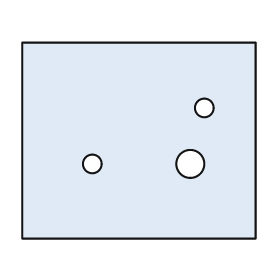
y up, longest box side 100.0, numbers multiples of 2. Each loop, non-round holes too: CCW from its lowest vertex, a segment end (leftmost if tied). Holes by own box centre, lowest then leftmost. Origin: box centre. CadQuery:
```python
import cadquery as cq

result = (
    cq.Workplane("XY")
    .moveTo(-50.0, -42.0)
    .lineTo(50.0, -42.0)
    .lineTo(50.0, 42.0)
    .lineTo(-50.0, 42.0)
    .close()
    .moveTo(-20.0, -10.0)
    .circle(4.0)
    .moveTo(22.0, -10.0)
    .circle(6.0)
    .moveTo(28.0, 14.0)
    .circle(4.0)
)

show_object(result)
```